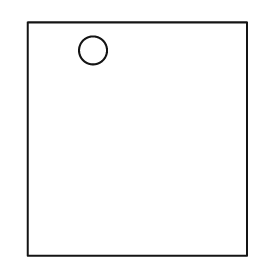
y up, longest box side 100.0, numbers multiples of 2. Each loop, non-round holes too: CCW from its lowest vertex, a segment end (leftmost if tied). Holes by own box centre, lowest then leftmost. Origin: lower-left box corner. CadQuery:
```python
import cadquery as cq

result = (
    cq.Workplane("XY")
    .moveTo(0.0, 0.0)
    .lineTo(94.0, 0.0)
    .lineTo(94.0, 100.0)
    .lineTo(0.0, 100.0)
    .close()
    .moveTo(28.0, 88.0)
    .circle(6.0)
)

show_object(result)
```